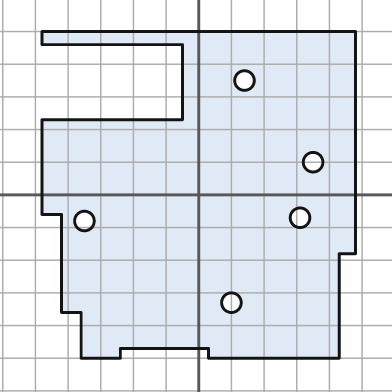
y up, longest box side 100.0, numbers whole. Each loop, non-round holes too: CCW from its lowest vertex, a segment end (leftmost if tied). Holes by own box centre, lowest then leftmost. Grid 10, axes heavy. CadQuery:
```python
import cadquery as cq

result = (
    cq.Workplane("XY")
    .moveTo(-36.0, -50.0)
    .lineTo(-24.0, -50.0)
    .lineTo(-24.0, -47.0)
    .lineTo(3.0, -47.0)
    .lineTo(3.0, -50.0)
    .lineTo(43.0, -50.0)
    .lineTo(43.0, -18.0)
    .lineTo(48.0, -18.0)
    .lineTo(48.0, 50.0)
    .lineTo(-48.0, 50.0)
    .lineTo(-48.0, 46.0)
    .lineTo(-5.0, 46.0)
    .lineTo(-5.0, 23.0)
    .lineTo(-48.0, 23.0)
    .lineTo(-48.0, -6.0)
    .lineTo(-42.0, -6.0)
    .lineTo(-42.0, -36.0)
    .lineTo(-36.0, -36.0)
    .close()
    .moveTo(10.0, -33.0)
    .circle(3.0)
    .moveTo(-35.0, -8.0)
    .circle(3.0)
    .moveTo(31.0, -7.0)
    .circle(3.0)
    .moveTo(35.0, 10.0)
    .circle(3.0)
    .moveTo(14.0, 35.0)
    .circle(3.0)
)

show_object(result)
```